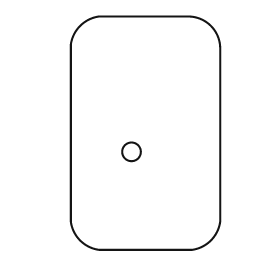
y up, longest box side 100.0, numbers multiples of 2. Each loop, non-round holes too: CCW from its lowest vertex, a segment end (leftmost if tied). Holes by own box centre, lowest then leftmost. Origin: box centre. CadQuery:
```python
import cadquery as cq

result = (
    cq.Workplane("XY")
    .moveTo(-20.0, -50.0)
    .lineTo(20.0, -50.0)
    .threePointArc((28.0, -46.0), (32.0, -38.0))
    .lineTo(32.0, 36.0)
    .threePointArc((28.0, 46.0), (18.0, 50.0))
    .lineTo(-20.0, 50.0)
    .threePointArc((-28.0, 46.0), (-32.0, 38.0))
    .lineTo(-32.0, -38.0)
    .threePointArc((-28.0, -46.0), (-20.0, -50.0))
    .close()
    .moveTo(-6.0, -8.0)
    .circle(4.0)
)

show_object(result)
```